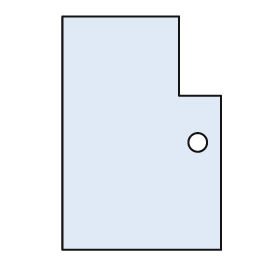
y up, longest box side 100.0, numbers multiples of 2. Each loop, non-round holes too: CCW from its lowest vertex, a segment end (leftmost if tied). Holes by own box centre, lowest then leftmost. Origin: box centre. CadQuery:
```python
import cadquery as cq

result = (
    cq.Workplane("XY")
    .moveTo(-34.0, -50.0)
    .lineTo(34.0, -50.0)
    .lineTo(34.0, 16.0)
    .lineTo(16.0, 16.0)
    .lineTo(16.0, 50.0)
    .lineTo(-34.0, 50.0)
    .close()
    .moveTo(24.0, -4.0)
    .circle(4.0)
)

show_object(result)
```